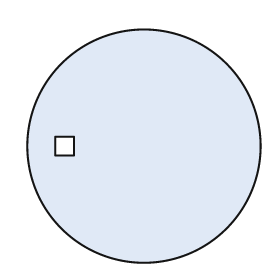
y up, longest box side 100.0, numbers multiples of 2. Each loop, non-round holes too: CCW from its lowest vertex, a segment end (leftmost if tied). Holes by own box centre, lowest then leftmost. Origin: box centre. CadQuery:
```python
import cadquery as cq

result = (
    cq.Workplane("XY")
    .moveTo(0.0, 0.0)
    .circle(50.0)
    .moveTo(-38.0, -4.0)
    .lineTo(-30.0, -4.0)
    .lineTo(-30.0, 4.0)
    .lineTo(-38.0, 4.0)
    .close()
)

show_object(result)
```